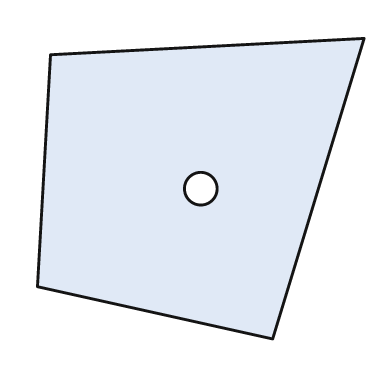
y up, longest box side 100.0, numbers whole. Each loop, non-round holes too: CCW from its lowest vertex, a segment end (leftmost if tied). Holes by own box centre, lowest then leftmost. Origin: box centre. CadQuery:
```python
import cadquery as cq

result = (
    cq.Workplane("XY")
    .moveTo(22.0, -46.0)
    .lineTo(50.0, 46.0)
    .lineTo(-46.0, 41.0)
    .lineTo(-50.0, -30.0)
    .close()
    .moveTo(0.0, 0.0)
    .circle(5.0)
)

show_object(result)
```